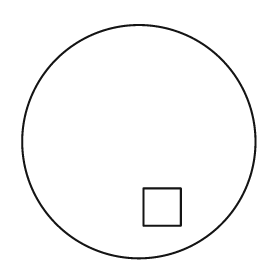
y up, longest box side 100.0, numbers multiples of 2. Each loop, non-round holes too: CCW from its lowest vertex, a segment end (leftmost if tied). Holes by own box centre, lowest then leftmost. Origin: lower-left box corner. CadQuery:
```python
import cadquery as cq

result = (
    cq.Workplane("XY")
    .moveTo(50.0, 50.0)
    .circle(50.0)
    .moveTo(52.0, 14.0)
    .lineTo(68.0, 14.0)
    .lineTo(68.0, 30.0)
    .lineTo(52.0, 30.0)
    .close()
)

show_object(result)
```